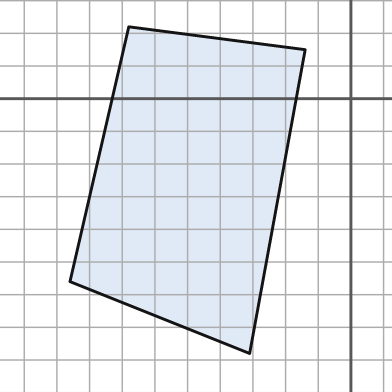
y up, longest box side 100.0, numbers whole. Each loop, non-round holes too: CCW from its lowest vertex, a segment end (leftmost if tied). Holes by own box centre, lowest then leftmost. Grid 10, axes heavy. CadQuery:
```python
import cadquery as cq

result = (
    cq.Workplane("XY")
    .moveTo(-31.0, -78.0)
    .lineTo(-14.0, 15.0)
    .lineTo(-68.0, 22.0)
    .lineTo(-86.0, -56.0)
    .close()
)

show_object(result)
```